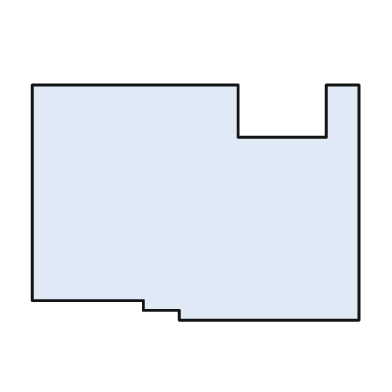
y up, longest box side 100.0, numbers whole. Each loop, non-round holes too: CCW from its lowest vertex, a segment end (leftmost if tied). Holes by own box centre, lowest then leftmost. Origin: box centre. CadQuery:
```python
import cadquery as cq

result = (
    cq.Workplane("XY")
    .moveTo(-5.0, -36.0)
    .lineTo(50.0, -36.0)
    .lineTo(50.0, 36.0)
    .lineTo(40.0, 36.0)
    .lineTo(40.0, 20.0)
    .lineTo(13.0, 20.0)
    .lineTo(13.0, 36.0)
    .lineTo(-50.0, 36.0)
    .lineTo(-50.0, -30.0)
    .lineTo(-16.0, -30.0)
    .lineTo(-16.0, -33.0)
    .lineTo(-5.0, -33.0)
    .close()
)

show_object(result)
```